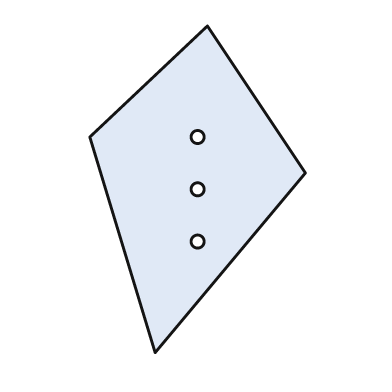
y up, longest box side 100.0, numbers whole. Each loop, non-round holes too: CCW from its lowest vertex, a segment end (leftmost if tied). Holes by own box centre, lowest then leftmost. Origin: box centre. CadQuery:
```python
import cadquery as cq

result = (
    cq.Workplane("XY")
    .moveTo(-13.0, -50.0)
    .lineTo(33.0, 5.0)
    .lineTo(3.0, 50.0)
    .lineTo(-33.0, 16.0)
    .close()
    .moveTo(0.0, -16.0)
    .circle(2.0)
    .moveTo(0.0, 0.0)
    .circle(2.0)
    .moveTo(0.0, 16.0)
    .circle(2.0)
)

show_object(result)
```